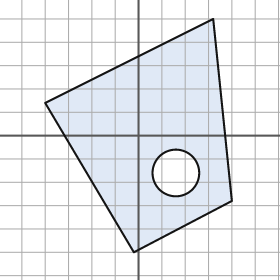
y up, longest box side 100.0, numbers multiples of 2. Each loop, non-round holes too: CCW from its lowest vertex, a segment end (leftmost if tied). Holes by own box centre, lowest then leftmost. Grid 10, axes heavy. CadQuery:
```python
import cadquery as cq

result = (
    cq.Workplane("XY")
    .moveTo(-2.0, -50.0)
    .lineTo(40.0, -28.0)
    .lineTo(32.0, 50.0)
    .lineTo(-40.0, 14.0)
    .close()
    .moveTo(16.0, -16.0)
    .circle(10.0)
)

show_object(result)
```